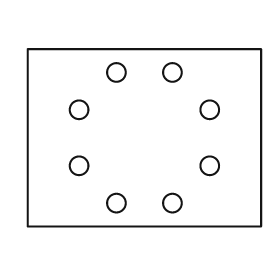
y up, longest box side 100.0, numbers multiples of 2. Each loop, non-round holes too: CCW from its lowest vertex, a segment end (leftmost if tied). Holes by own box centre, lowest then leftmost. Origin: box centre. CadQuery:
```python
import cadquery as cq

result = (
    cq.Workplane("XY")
    .moveTo(-50.0, -38.0)
    .lineTo(50.0, -38.0)
    .lineTo(50.0, 38.0)
    .lineTo(-50.0, 38.0)
    .close()
    .moveTo(-12.0, -28.0)
    .circle(4.0)
    .moveTo(12.0, -28.0)
    .circle(4.0)
    .moveTo(-28.0, -12.0)
    .circle(4.0)
    .moveTo(28.0, -12.0)
    .circle(4.0)
    .moveTo(-28.0, 12.0)
    .circle(4.0)
    .moveTo(28.0, 12.0)
    .circle(4.0)
    .moveTo(-12.0, 28.0)
    .circle(4.0)
    .moveTo(12.0, 28.0)
    .circle(4.0)
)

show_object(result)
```